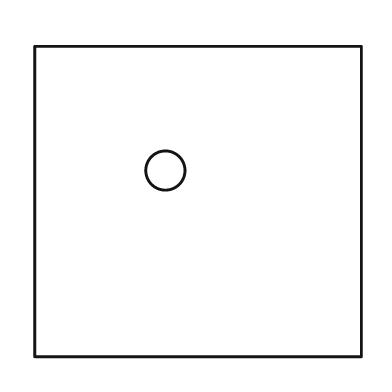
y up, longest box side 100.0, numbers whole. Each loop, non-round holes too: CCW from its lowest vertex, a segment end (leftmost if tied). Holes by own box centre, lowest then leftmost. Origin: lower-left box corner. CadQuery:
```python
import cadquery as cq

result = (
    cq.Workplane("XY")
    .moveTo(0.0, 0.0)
    .lineTo(100.0, 0.0)
    .lineTo(100.0, 95.0)
    .lineTo(0.0, 95.0)
    .close()
    .moveTo(40.0, 57.0)
    .circle(6.0)
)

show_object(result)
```